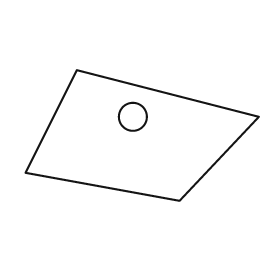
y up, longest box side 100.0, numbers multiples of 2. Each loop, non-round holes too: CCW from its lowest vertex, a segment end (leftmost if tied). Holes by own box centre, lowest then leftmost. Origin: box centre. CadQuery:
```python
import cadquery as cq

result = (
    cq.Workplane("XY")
    .moveTo(16.0, -28.0)
    .lineTo(50.0, 8.0)
    .lineTo(-28.0, 28.0)
    .lineTo(-50.0, -16.0)
    .close()
    .moveTo(-4.0, 8.0)
    .circle(6.0)
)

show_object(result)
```